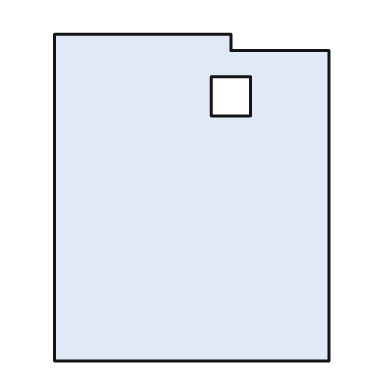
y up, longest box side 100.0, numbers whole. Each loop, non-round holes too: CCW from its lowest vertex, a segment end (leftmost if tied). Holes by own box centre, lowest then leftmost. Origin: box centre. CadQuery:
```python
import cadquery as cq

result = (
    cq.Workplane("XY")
    .moveTo(-42.0, -50.0)
    .lineTo(42.0, -50.0)
    .lineTo(42.0, 45.0)
    .lineTo(12.0, 45.0)
    .lineTo(12.0, 50.0)
    .lineTo(-42.0, 50.0)
    .close()
    .moveTo(6.0, 25.0)
    .lineTo(18.0, 25.0)
    .lineTo(18.0, 37.0)
    .lineTo(6.0, 37.0)
    .close()
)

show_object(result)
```